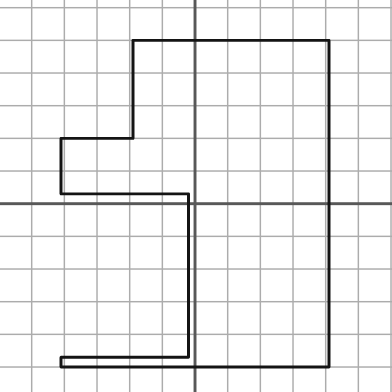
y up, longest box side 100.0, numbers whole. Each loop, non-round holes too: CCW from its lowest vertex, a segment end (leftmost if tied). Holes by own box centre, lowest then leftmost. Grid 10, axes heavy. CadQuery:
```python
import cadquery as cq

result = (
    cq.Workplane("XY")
    .moveTo(-41.0, -50.0)
    .lineTo(41.0, -50.0)
    .lineTo(41.0, 50.0)
    .lineTo(-19.0, 50.0)
    .lineTo(-19.0, 20.0)
    .lineTo(-41.0, 20.0)
    .lineTo(-41.0, 3.0)
    .lineTo(-2.0, 3.0)
    .lineTo(-2.0, -47.0)
    .lineTo(-41.0, -47.0)
    .close()
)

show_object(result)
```